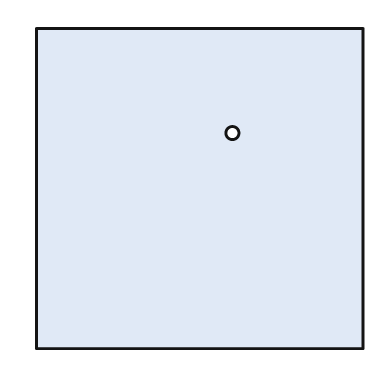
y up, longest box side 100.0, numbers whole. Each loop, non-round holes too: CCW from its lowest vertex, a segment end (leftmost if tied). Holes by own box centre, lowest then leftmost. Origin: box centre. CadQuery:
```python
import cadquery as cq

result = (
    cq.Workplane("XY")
    .moveTo(-50.0, -49.0)
    .lineTo(50.0, -49.0)
    .lineTo(50.0, 49.0)
    .lineTo(-50.0, 49.0)
    .close()
    .moveTo(10.0, 17.0)
    .circle(2.0)
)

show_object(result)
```